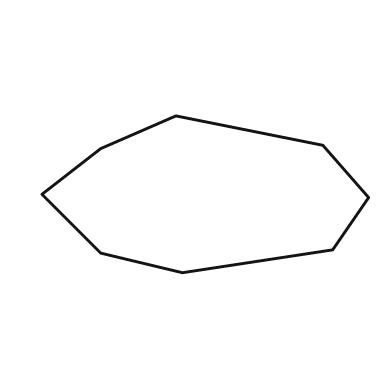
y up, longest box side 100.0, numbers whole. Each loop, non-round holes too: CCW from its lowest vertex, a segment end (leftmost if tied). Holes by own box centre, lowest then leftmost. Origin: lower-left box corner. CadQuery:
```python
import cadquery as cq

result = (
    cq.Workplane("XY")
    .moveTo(43.0, 0.0)
    .lineTo(89.0, 7.0)
    .lineTo(100.0, 23.0)
    .lineTo(86.0, 39.0)
    .lineTo(41.0, 48.0)
    .lineTo(18.0, 38.0)
    .lineTo(0.0, 24.0)
    .lineTo(18.0, 6.0)
    .close()
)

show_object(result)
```